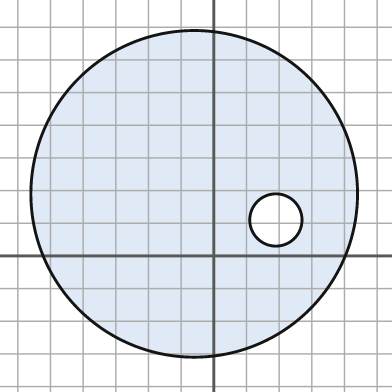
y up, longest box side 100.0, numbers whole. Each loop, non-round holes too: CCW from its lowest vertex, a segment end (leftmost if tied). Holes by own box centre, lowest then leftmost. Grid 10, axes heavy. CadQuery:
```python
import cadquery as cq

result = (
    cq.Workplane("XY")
    .moveTo(-6.0, 19.0)
    .circle(50.0)
    .moveTo(19.0, 11.0)
    .circle(8.0)
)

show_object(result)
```